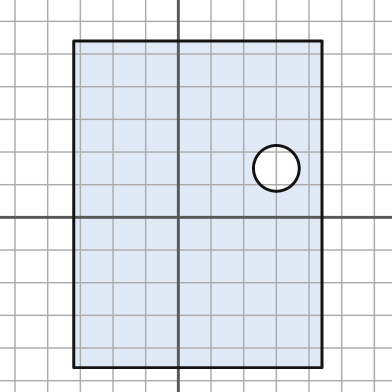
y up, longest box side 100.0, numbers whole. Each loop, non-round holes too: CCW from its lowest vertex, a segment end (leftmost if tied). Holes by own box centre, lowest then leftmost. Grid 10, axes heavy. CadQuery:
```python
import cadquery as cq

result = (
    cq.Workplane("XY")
    .moveTo(-32.0, -46.0)
    .lineTo(44.0, -46.0)
    .lineTo(44.0, 54.0)
    .lineTo(-32.0, 54.0)
    .close()
    .moveTo(30.0, 15.0)
    .circle(7.0)
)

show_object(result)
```